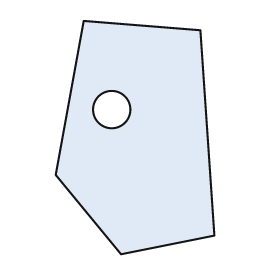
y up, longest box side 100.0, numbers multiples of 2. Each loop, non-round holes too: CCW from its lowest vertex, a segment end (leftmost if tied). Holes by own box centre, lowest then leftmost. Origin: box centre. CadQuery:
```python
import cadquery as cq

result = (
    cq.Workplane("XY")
    .moveTo(-6.0, -50.0)
    .lineTo(34.0, -42.0)
    .lineTo(28.0, 46.0)
    .lineTo(-22.0, 50.0)
    .lineTo(-34.0, -16.0)
    .close()
    .moveTo(-10.0, 12.0)
    .circle(8.0)
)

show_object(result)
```